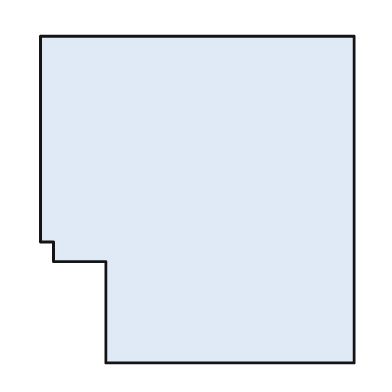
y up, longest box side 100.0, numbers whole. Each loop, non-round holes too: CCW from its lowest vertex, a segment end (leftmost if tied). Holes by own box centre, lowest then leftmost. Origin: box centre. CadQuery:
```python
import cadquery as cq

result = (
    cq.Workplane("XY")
    .moveTo(-28.0, -50.0)
    .lineTo(48.0, -50.0)
    .lineTo(48.0, 50.0)
    .lineTo(-48.0, 50.0)
    .lineTo(-48.0, -13.0)
    .lineTo(-44.0, -13.0)
    .lineTo(-44.0, -19.0)
    .lineTo(-28.0, -19.0)
    .close()
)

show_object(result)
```